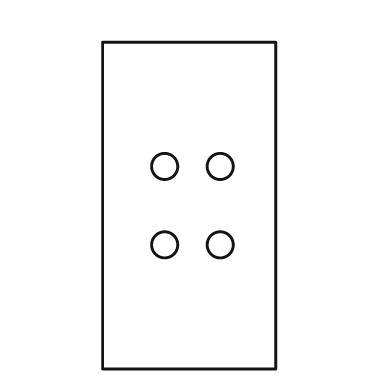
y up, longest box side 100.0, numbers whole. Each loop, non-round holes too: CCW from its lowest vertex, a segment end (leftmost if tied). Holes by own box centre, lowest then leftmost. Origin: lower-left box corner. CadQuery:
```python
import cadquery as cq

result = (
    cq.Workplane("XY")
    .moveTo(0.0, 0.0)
    .lineTo(53.0, 0.0)
    .lineTo(53.0, 100.0)
    .lineTo(0.0, 100.0)
    .close()
    .moveTo(19.0, 38.0)
    .circle(4.0)
    .moveTo(36.0, 38.0)
    .circle(4.0)
    .moveTo(19.0, 62.0)
    .circle(4.0)
    .moveTo(36.0, 62.0)
    .circle(4.0)
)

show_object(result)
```